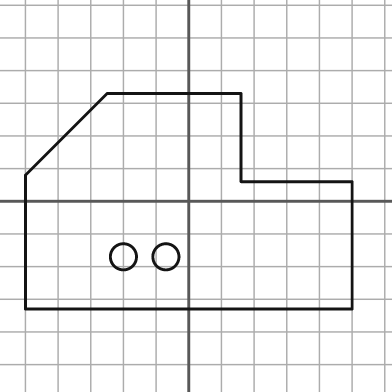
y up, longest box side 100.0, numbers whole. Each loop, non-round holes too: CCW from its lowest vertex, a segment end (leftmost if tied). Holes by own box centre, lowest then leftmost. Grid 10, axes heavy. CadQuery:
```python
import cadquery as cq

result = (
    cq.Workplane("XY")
    .moveTo(-50.0, -33.0)
    .lineTo(50.0, -33.0)
    .lineTo(50.0, 6.0)
    .lineTo(16.0, 6.0)
    .lineTo(16.0, 33.0)
    .lineTo(-25.0, 33.0)
    .lineTo(-50.0, 8.0)
    .close()
    .moveTo(-20.0, -17.0)
    .circle(4.0)
    .moveTo(-7.0, -17.0)
    .circle(4.0)
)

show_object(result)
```